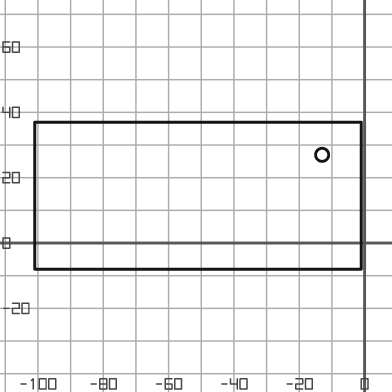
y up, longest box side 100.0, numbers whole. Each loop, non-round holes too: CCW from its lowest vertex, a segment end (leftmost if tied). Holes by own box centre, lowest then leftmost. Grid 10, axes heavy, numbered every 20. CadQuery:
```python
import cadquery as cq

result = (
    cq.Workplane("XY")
    .moveTo(-101.0, -8.0)
    .lineTo(-1.0, -8.0)
    .lineTo(-1.0, 37.0)
    .lineTo(-101.0, 37.0)
    .close()
    .moveTo(-13.0, 27.0)
    .circle(2.0)
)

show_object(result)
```